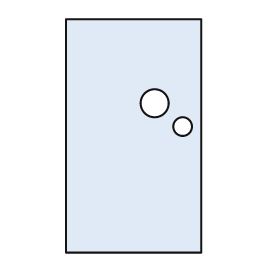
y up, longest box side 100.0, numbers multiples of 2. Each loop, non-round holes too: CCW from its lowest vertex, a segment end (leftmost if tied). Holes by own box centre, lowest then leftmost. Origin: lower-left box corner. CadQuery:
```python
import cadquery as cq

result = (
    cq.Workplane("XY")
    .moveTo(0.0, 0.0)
    .lineTo(58.0, 0.0)
    .lineTo(58.0, 100.0)
    .lineTo(0.0, 100.0)
    .close()
    .moveTo(50.0, 54.0)
    .circle(4.0)
    .moveTo(38.0, 64.0)
    .circle(6.0)
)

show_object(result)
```